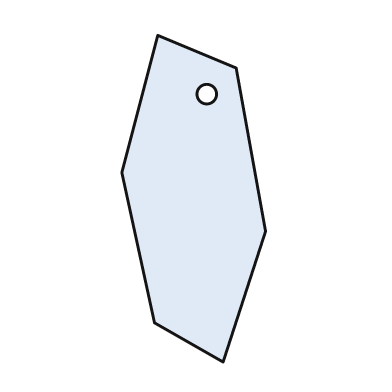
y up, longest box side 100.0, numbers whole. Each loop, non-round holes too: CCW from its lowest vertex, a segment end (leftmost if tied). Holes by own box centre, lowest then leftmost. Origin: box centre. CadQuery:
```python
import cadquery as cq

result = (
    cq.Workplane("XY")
    .moveTo(9.0, -50.0)
    .lineTo(22.0, -10.0)
    .lineTo(13.0, 40.0)
    .lineTo(-11.0, 50.0)
    .lineTo(-22.0, 8.0)
    .lineTo(-12.0, -38.0)
    .close()
    .moveTo(4.0, 32.0)
    .circle(3.0)
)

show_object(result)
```